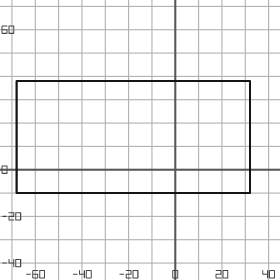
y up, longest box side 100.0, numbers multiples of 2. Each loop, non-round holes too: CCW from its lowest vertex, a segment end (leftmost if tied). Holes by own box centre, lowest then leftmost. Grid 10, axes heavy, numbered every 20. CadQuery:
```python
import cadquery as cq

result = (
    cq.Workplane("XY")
    .moveTo(-68.0, -10.0)
    .lineTo(32.0, -10.0)
    .lineTo(32.0, 38.0)
    .lineTo(-68.0, 38.0)
    .close()
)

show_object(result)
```